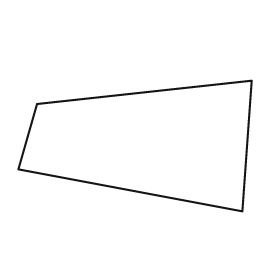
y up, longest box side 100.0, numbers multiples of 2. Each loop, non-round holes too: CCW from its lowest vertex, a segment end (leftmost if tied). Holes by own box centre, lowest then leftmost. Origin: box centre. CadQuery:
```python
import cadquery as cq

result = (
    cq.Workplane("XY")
    .moveTo(46.0, -28.0)
    .lineTo(50.0, 28.0)
    .lineTo(-42.0, 18.0)
    .lineTo(-50.0, -10.0)
    .close()
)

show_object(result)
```